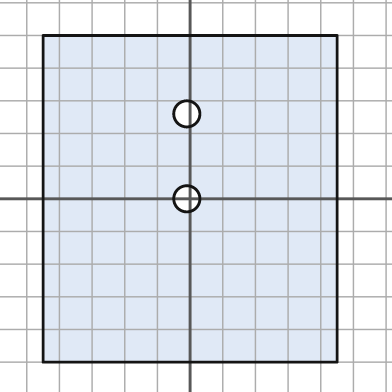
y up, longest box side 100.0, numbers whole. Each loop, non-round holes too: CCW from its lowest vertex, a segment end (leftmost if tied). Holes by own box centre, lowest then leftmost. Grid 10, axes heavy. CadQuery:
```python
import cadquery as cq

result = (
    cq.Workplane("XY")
    .moveTo(-45.0, -50.0)
    .lineTo(45.0, -50.0)
    .lineTo(45.0, 50.0)
    .lineTo(-45.0, 50.0)
    .close()
    .moveTo(-1.0, 0.0)
    .circle(4.0)
    .moveTo(-1.0, 26.0)
    .circle(4.0)
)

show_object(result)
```